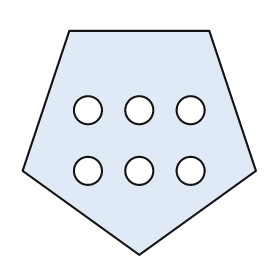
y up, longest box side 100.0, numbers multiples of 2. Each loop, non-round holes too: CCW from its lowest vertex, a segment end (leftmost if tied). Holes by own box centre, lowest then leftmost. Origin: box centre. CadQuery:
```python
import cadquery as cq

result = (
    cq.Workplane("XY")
    .moveTo(0.0, -48.0)
    .lineTo(50.0, -12.0)
    .lineTo(30.0, 48.0)
    .lineTo(-30.0, 48.0)
    .lineTo(-50.0, -12.0)
    .close()
    .moveTo(-22.0, -12.0)
    .circle(6.0)
    .moveTo(0.0, -12.0)
    .circle(6.0)
    .moveTo(22.0, -12.0)
    .circle(6.0)
    .moveTo(-22.0, 14.0)
    .circle(6.0)
    .moveTo(0.0, 14.0)
    .circle(6.0)
    .moveTo(22.0, 14.0)
    .circle(6.0)
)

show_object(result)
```